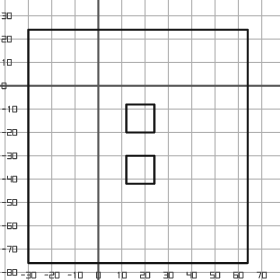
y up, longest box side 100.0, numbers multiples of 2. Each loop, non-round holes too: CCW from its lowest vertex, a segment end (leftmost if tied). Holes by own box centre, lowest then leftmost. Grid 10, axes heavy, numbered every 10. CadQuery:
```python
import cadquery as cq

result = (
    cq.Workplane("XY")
    .moveTo(-30.0, -76.0)
    .lineTo(64.0, -76.0)
    .lineTo(64.0, 24.0)
    .lineTo(-30.0, 24.0)
    .close()
    .moveTo(12.0, -42.0)
    .lineTo(24.0, -42.0)
    .lineTo(24.0, -30.0)
    .lineTo(12.0, -30.0)
    .close()
    .moveTo(12.0, -20.0)
    .lineTo(24.0, -20.0)
    .lineTo(24.0, -8.0)
    .lineTo(12.0, -8.0)
    .close()
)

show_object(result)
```